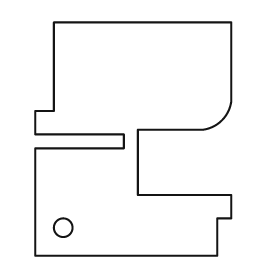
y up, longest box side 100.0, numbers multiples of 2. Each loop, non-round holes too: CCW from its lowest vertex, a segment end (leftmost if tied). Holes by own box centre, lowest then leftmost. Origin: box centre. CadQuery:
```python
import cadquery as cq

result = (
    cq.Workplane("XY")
    .moveTo(-42.0, -50.0)
    .lineTo(36.0, -50.0)
    .lineTo(36.0, -34.0)
    .lineTo(42.0, -34.0)
    .lineTo(42.0, -24.0)
    .lineTo(2.0, -24.0)
    .lineTo(2.0, 4.0)
    .lineTo(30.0, 4.0)
    .threePointArc((38.0, 8.0), (42.0, 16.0))
    .lineTo(42.0, 50.0)
    .lineTo(-34.0, 50.0)
    .lineTo(-34.0, 12.0)
    .lineTo(-42.0, 12.0)
    .lineTo(-42.0, 2.0)
    .lineTo(-4.0, 2.0)
    .lineTo(-4.0, -4.0)
    .lineTo(-42.0, -4.0)
    .close()
    .moveTo(-30.0, -38.0)
    .circle(4.0)
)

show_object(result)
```